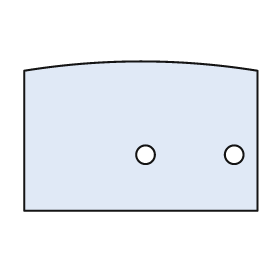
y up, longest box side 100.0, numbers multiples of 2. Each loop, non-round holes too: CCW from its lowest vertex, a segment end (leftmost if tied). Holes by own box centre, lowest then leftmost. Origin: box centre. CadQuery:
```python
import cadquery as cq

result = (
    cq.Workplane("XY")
    .moveTo(-50.0, -32.0)
    .lineTo(50.0, -32.0)
    .lineTo(50.0, 28.0)
    .threePointArc((0.0, 32.0), (-50.0, 28.0))
    .close()
    .moveTo(2.0, -8.0)
    .circle(4.0)
    .moveTo(40.0, -8.0)
    .circle(4.0)
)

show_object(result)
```